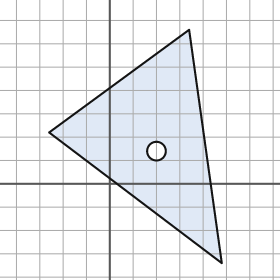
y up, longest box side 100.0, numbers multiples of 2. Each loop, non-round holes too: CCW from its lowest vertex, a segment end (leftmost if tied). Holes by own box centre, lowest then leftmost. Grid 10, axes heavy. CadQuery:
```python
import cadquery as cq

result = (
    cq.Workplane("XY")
    .moveTo(48.0, -34.0)
    .lineTo(34.0, 66.0)
    .lineTo(-26.0, 22.0)
    .close()
    .moveTo(20.0, 14.0)
    .circle(4.0)
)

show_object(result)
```